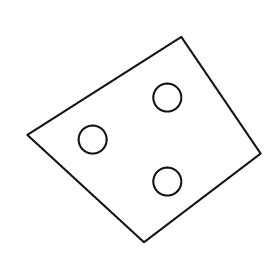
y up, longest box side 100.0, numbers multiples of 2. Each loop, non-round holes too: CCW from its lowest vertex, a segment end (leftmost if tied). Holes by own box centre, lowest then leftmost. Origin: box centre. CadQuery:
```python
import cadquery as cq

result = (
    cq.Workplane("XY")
    .moveTo(0.0, -44.0)
    .lineTo(50.0, -6.0)
    .lineTo(16.0, 44.0)
    .lineTo(-50.0, 2.0)
    .close()
    .moveTo(10.0, -18.0)
    .circle(6.0)
    .moveTo(-22.0, 0.0)
    .circle(6.0)
    .moveTo(10.0, 18.0)
    .circle(6.0)
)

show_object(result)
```